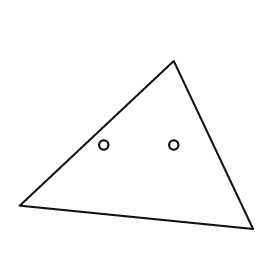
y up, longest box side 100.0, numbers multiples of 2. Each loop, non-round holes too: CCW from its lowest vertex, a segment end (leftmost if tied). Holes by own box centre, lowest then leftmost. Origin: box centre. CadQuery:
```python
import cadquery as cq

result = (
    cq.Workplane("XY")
    .moveTo(50.0, -36.0)
    .lineTo(16.0, 36.0)
    .lineTo(-50.0, -26.0)
    .close()
    .moveTo(-14.0, 0.0)
    .circle(2.0)
    .moveTo(16.0, 0.0)
    .circle(2.0)
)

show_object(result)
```